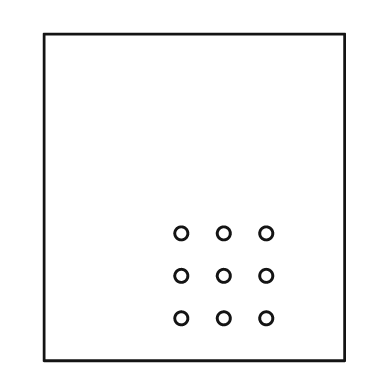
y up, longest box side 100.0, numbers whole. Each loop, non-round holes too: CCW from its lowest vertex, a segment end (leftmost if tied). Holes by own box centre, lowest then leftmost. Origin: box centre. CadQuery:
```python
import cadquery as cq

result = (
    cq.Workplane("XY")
    .moveTo(-46.0, -50.0)
    .lineTo(46.0, -50.0)
    .lineTo(46.0, 50.0)
    .lineTo(-46.0, 50.0)
    .close()
    .moveTo(-4.0, -37.0)
    .circle(2.0)
    .moveTo(9.0, -37.0)
    .circle(2.0)
    .moveTo(22.0, -37.0)
    .circle(2.0)
    .moveTo(-4.0, -24.0)
    .circle(2.0)
    .moveTo(9.0, -24.0)
    .circle(2.0)
    .moveTo(22.0, -24.0)
    .circle(2.0)
    .moveTo(-4.0, -11.0)
    .circle(2.0)
    .moveTo(9.0, -11.0)
    .circle(2.0)
    .moveTo(22.0, -11.0)
    .circle(2.0)
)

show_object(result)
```